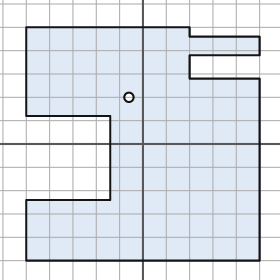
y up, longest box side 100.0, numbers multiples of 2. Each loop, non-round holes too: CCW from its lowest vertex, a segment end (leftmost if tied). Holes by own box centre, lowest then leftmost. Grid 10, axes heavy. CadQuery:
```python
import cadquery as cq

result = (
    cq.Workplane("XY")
    .moveTo(-50.0, -50.0)
    .lineTo(50.0, -50.0)
    .lineTo(50.0, 28.0)
    .lineTo(20.0, 28.0)
    .lineTo(20.0, 38.0)
    .lineTo(50.0, 38.0)
    .lineTo(50.0, 46.0)
    .lineTo(20.0, 46.0)
    .lineTo(20.0, 50.0)
    .lineTo(-50.0, 50.0)
    .lineTo(-50.0, 12.0)
    .lineTo(-14.0, 12.0)
    .lineTo(-14.0, -24.0)
    .lineTo(-50.0, -24.0)
    .close()
    .moveTo(-6.0, 20.0)
    .circle(2.0)
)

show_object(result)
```